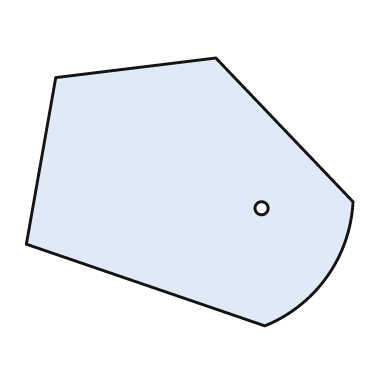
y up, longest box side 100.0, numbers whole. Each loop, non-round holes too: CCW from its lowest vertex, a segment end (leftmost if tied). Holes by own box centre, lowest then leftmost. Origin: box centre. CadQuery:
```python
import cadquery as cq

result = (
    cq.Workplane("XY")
    .moveTo(23.0, -41.0)
    .threePointArc((42.0, -26.0), (50.0, -3.0))
    .lineTo(8.0, 41.0)
    .lineTo(-41.0, 35.0)
    .lineTo(-50.0, -16.0)
    .close()
    .moveTo(22.0, -5.0)
    .circle(2.0)
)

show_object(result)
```